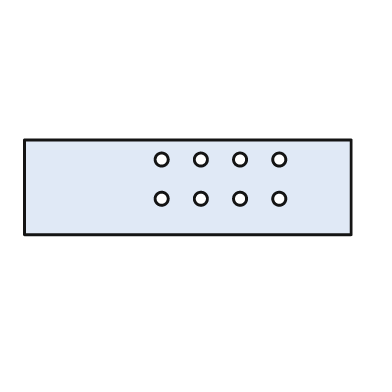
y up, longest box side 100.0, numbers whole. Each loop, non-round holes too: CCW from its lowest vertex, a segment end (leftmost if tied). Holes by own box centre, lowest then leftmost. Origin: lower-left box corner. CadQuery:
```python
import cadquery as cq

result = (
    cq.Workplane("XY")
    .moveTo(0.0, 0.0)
    .lineTo(100.0, 0.0)
    .lineTo(100.0, 29.0)
    .lineTo(0.0, 29.0)
    .close()
    .moveTo(42.0, 11.0)
    .circle(2.0)
    .moveTo(54.0, 11.0)
    .circle(2.0)
    .moveTo(66.0, 11.0)
    .circle(2.0)
    .moveTo(78.0, 11.0)
    .circle(2.0)
    .moveTo(42.0, 23.0)
    .circle(2.0)
    .moveTo(54.0, 23.0)
    .circle(2.0)
    .moveTo(66.0, 23.0)
    .circle(2.0)
    .moveTo(78.0, 23.0)
    .circle(2.0)
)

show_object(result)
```